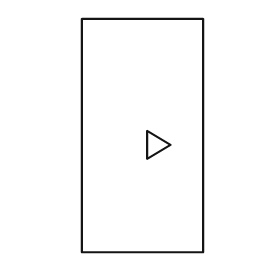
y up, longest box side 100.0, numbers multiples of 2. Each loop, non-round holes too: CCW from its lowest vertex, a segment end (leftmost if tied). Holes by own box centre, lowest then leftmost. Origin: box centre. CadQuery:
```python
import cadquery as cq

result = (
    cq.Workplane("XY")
    .moveTo(-26.0, -50.0)
    .lineTo(26.0, -50.0)
    .lineTo(26.0, 50.0)
    .lineTo(-26.0, 50.0)
    .close()
    .moveTo(2.0, -10.0)
    .lineTo(12.0, -4.0)
    .lineTo(2.0, 2.0)
    .close()
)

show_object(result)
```